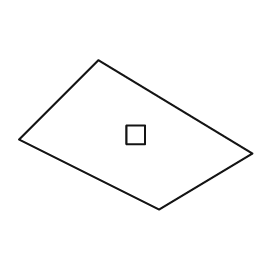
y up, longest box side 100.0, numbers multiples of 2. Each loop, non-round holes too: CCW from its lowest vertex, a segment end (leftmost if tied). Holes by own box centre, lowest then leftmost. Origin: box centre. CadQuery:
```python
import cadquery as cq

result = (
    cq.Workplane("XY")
    .moveTo(10.0, -32.0)
    .lineTo(50.0, -8.0)
    .lineTo(-16.0, 32.0)
    .lineTo(-50.0, -2.0)
    .close()
    .moveTo(-4.0, -4.0)
    .lineTo(4.0, -4.0)
    .lineTo(4.0, 4.0)
    .lineTo(-4.0, 4.0)
    .close()
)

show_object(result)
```